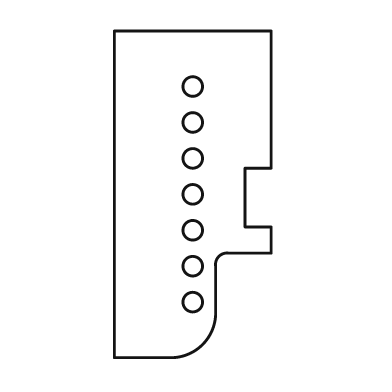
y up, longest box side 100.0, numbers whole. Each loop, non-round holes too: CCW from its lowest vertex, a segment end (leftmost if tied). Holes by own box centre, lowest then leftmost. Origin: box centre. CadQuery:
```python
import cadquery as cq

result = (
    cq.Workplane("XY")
    .moveTo(-24.0, -50.0)
    .lineTo(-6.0, -50.0)
    .threePointArc((3.0, -46.0), (7.0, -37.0))
    .lineTo(7.0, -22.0)
    .threePointArc((8.0, -19.0), (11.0, -18.0))
    .lineTo(24.0, -18.0)
    .lineTo(24.0, -10.0)
    .lineTo(16.0, -10.0)
    .lineTo(16.0, 8.0)
    .lineTo(24.0, 8.0)
    .lineTo(24.0, 50.0)
    .lineTo(-24.0, 50.0)
    .close()
    .moveTo(0.0, -33.0)
    .circle(3.0)
    .moveTo(0.0, -22.0)
    .circle(3.0)
    .moveTo(0.0, -11.0)
    .circle(3.0)
    .moveTo(0.0, 0.0)
    .circle(3.0)
    .moveTo(0.0, 11.0)
    .circle(3.0)
    .moveTo(0.0, 22.0)
    .circle(3.0)
    .moveTo(0.0, 33.0)
    .circle(3.0)
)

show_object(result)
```